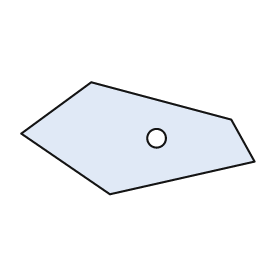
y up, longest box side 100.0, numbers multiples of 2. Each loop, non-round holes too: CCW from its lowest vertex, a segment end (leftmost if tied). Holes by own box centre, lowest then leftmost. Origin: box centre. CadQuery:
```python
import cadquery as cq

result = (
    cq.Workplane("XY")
    .moveTo(-12.0, -24.0)
    .lineTo(50.0, -10.0)
    .lineTo(40.0, 8.0)
    .lineTo(-20.0, 24.0)
    .lineTo(-50.0, 2.0)
    .close()
    .moveTo(8.0, 0.0)
    .circle(4.0)
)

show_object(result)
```